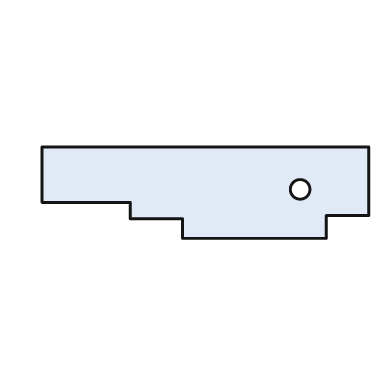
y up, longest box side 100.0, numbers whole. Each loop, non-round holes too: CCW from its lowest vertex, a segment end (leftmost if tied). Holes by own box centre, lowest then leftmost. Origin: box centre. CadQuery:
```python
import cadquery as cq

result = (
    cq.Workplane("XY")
    .moveTo(-7.0, -14.0)
    .lineTo(37.0, -14.0)
    .lineTo(37.0, -7.0)
    .lineTo(50.0, -7.0)
    .lineTo(50.0, 14.0)
    .lineTo(-50.0, 14.0)
    .lineTo(-50.0, -3.0)
    .lineTo(-23.0, -3.0)
    .lineTo(-23.0, -8.0)
    .lineTo(-7.0, -8.0)
    .close()
    .moveTo(29.0, 1.0)
    .circle(3.0)
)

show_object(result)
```